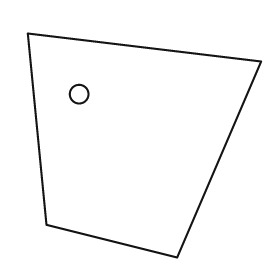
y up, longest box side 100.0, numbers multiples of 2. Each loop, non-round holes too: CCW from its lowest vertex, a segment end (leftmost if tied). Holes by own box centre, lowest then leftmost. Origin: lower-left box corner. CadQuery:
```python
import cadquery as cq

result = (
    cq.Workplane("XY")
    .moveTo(64.0, 0.0)
    .lineTo(100.0, 84.0)
    .lineTo(0.0, 96.0)
    .lineTo(8.0, 14.0)
    .close()
    .moveTo(22.0, 70.0)
    .circle(4.0)
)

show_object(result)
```